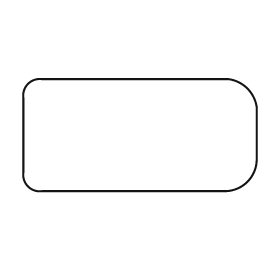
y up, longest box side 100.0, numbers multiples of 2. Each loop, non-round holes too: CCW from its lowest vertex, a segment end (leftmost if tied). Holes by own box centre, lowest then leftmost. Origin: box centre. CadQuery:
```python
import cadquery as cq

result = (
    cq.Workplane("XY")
    .moveTo(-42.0, -24.0)
    .lineTo(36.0, -24.0)
    .threePointArc((46.0, -20.0), (50.0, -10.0))
    .lineTo(50.0, 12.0)
    .threePointArc((46.0, 20.0), (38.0, 24.0))
    .lineTo(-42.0, 24.0)
    .threePointArc((-48.0, 22.0), (-50.0, 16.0))
    .lineTo(-50.0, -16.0)
    .threePointArc((-48.0, -22.0), (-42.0, -24.0))
    .close()
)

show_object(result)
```